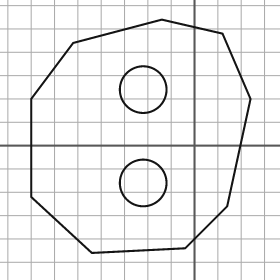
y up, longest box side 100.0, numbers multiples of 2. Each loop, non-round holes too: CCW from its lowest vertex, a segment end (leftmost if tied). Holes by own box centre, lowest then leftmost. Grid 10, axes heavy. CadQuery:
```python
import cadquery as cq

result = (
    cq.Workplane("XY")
    .moveTo(-44.0, -46.0)
    .lineTo(-4.0, -44.0)
    .lineTo(14.0, -26.0)
    .lineTo(24.0, 20.0)
    .lineTo(12.0, 48.0)
    .lineTo(-14.0, 54.0)
    .lineTo(-52.0, 44.0)
    .lineTo(-70.0, 20.0)
    .lineTo(-70.0, -22.0)
    .close()
    .moveTo(-22.0, -16.0)
    .circle(10.0)
    .moveTo(-22.0, 24.0)
    .circle(10.0)
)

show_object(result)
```